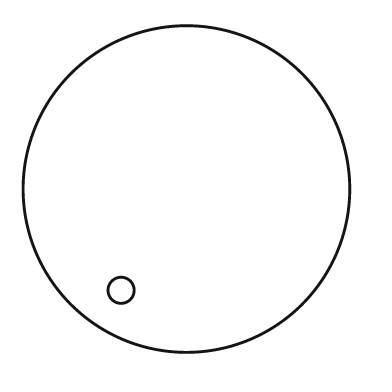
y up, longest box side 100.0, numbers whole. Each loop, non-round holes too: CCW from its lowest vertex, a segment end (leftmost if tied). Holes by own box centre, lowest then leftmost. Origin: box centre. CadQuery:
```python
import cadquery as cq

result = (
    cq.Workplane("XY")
    .moveTo(0.0, 0.0)
    .circle(50.0)
    .moveTo(-20.0, -31.0)
    .circle(4.0)
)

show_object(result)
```